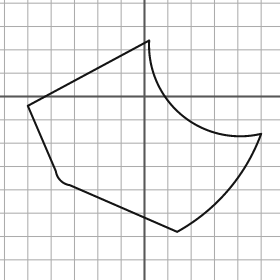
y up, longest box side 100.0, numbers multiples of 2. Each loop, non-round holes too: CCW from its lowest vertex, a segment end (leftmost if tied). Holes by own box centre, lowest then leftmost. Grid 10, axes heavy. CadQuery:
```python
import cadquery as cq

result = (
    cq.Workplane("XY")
    .moveTo(14.0, -58.0)
    .threePointArc((36.0, -40.0), (50.0, -16.0))
    .threePointArc((16.0, -8.0), (2.0, 24.0))
    .lineTo(-50.0, -4.0)
    .lineTo(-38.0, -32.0)
    .threePointArc((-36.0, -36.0), (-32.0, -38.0))
    .close()
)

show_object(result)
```